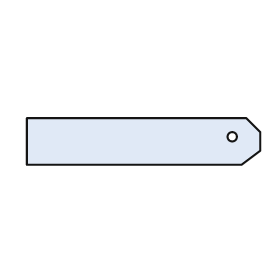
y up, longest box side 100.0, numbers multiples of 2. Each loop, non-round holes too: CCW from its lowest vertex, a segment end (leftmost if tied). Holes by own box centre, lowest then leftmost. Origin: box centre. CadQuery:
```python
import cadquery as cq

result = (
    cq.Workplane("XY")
    .moveTo(-50.0, -10.0)
    .lineTo(42.0, -10.0)
    .lineTo(50.0, -4.0)
    .lineTo(50.0, 4.0)
    .lineTo(44.0, 10.0)
    .lineTo(-50.0, 10.0)
    .close()
    .moveTo(38.0, 2.0)
    .circle(2.0)
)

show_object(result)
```